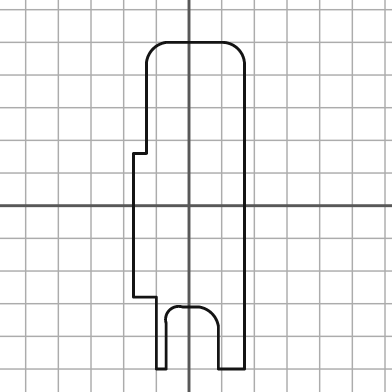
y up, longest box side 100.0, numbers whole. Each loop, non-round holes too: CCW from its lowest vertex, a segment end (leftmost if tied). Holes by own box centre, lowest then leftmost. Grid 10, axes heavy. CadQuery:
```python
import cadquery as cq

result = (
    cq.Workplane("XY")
    .moveTo(-10.0, -50.0)
    .lineTo(-7.0, -50.0)
    .lineTo(-7.0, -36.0)
    .threePointArc((-6.0, -32.0), (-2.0, -31.0))
    .lineTo(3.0, -31.0)
    .threePointArc((7.0, -33.0), (9.0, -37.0))
    .lineTo(9.0, -50.0)
    .lineTo(17.0, -50.0)
    .lineTo(17.0, 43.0)
    .threePointArc((15.0, 48.0), (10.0, 50.0))
    .lineTo(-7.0, 50.0)
    .threePointArc((-11.0, 48.0), (-13.0, 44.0))
    .lineTo(-13.0, 16.0)
    .lineTo(-17.0, 16.0)
    .lineTo(-17.0, -28.0)
    .lineTo(-10.0, -28.0)
    .close()
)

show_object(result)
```